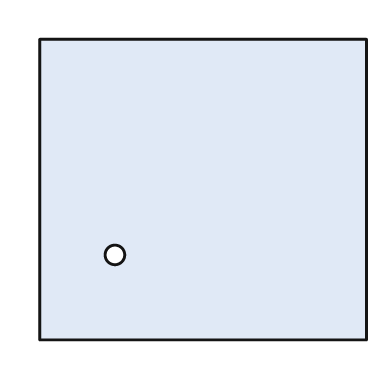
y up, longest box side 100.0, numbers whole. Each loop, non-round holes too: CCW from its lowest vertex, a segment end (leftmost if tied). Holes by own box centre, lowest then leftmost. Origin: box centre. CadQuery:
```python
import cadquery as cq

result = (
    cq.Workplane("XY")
    .moveTo(-50.0, -46.0)
    .lineTo(50.0, -46.0)
    .lineTo(50.0, 46.0)
    .lineTo(-50.0, 46.0)
    .close()
    .moveTo(-27.0, -20.0)
    .circle(3.0)
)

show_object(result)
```